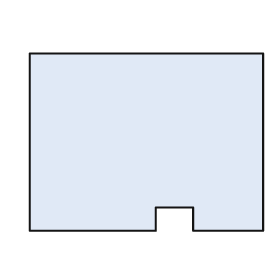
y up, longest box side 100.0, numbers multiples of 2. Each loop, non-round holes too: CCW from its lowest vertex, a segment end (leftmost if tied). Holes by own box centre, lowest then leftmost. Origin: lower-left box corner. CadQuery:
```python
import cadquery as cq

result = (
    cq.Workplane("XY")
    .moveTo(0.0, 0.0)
    .lineTo(54.0, 0.0)
    .lineTo(54.0, 10.0)
    .lineTo(70.0, 10.0)
    .lineTo(70.0, 0.0)
    .lineTo(100.0, 0.0)
    .lineTo(100.0, 76.0)
    .lineTo(0.0, 76.0)
    .close()
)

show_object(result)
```